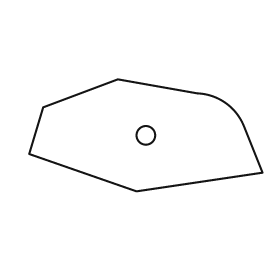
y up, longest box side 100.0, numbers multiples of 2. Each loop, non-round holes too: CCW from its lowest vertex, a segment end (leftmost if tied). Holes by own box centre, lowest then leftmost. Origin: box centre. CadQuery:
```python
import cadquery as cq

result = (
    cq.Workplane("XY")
    .moveTo(-4.0, -24.0)
    .lineTo(50.0, -16.0)
    .lineTo(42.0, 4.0)
    .threePointArc((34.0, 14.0), (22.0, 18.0))
    .lineTo(-12.0, 24.0)
    .lineTo(-44.0, 12.0)
    .lineTo(-50.0, -8.0)
    .close()
    .moveTo(0.0, 0.0)
    .circle(4.0)
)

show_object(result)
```